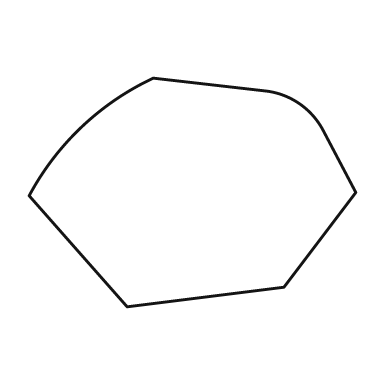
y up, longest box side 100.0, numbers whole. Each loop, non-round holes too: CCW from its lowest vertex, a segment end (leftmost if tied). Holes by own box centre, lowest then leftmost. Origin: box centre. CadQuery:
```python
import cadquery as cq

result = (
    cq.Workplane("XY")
    .moveTo(-20.0, -35.0)
    .lineTo(28.0, -29.0)
    .lineTo(50.0, 0.0)
    .lineTo(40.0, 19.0)
    .threePointArc((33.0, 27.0), (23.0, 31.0))
    .lineTo(-12.0, 35.0)
    .threePointArc((-34.0, 20.0), (-50.0, -1.0))
    .close()
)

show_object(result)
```